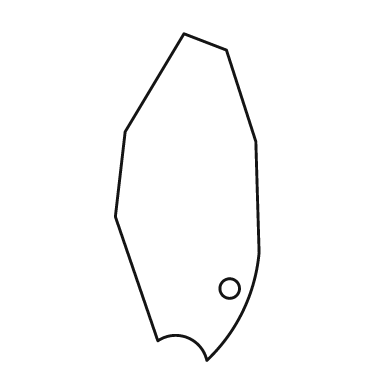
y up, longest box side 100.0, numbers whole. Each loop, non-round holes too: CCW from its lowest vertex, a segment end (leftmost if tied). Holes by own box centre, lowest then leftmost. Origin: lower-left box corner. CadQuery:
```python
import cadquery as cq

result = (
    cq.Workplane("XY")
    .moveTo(28.0, 0.0)
    .threePointArc((39.0, 15.0), (44.0, 33.0))
    .lineTo(43.0, 67.0)
    .lineTo(34.0, 95.0)
    .lineTo(21.0, 100.0)
    .lineTo(3.0, 70.0)
    .lineTo(0.0, 44.0)
    .lineTo(13.0, 6.0)
    .threePointArc((22.0, 7.0), (28.0, 0.0))
    .close()
    .moveTo(35.0, 22.0)
    .circle(3.0)
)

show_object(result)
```